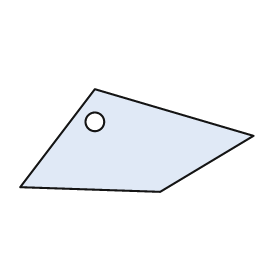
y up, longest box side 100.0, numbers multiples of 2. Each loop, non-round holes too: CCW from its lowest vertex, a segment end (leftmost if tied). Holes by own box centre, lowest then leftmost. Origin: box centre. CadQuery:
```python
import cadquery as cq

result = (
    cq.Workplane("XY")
    .moveTo(10.0, -22.0)
    .lineTo(50.0, 2.0)
    .lineTo(-18.0, 22.0)
    .lineTo(-50.0, -20.0)
    .close()
    .moveTo(-18.0, 8.0)
    .circle(4.0)
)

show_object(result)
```